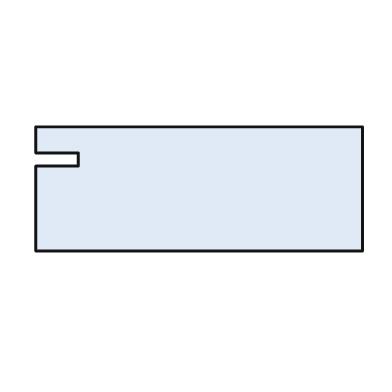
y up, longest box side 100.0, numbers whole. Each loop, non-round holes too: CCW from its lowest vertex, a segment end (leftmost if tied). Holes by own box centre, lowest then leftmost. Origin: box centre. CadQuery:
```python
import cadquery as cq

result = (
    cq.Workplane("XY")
    .moveTo(-50.0, -19.0)
    .lineTo(50.0, -19.0)
    .lineTo(50.0, 19.0)
    .lineTo(-50.0, 19.0)
    .lineTo(-50.0, 11.0)
    .lineTo(-37.0, 11.0)
    .lineTo(-37.0, 7.0)
    .lineTo(-50.0, 7.0)
    .close()
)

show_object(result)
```